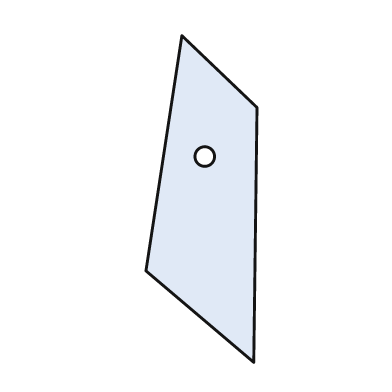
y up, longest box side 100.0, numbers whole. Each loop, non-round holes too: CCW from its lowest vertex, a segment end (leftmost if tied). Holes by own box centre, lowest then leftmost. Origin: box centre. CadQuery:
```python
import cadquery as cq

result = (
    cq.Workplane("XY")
    .moveTo(16.0, -50.0)
    .lineTo(17.0, 28.0)
    .lineTo(-6.0, 50.0)
    .lineTo(-17.0, -22.0)
    .close()
    .moveTo(1.0, 13.0)
    .circle(3.0)
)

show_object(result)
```